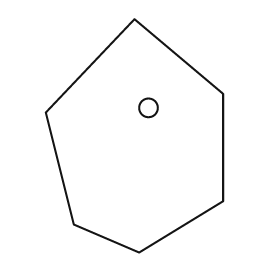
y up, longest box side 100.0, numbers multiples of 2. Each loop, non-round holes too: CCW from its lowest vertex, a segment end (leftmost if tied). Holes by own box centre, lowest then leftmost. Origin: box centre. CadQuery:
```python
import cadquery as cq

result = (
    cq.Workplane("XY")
    .moveTo(2.0, -50.0)
    .lineTo(38.0, -28.0)
    .lineTo(38.0, 18.0)
    .lineTo(0.0, 50.0)
    .lineTo(-38.0, 10.0)
    .lineTo(-26.0, -38.0)
    .close()
    .moveTo(6.0, 12.0)
    .circle(4.0)
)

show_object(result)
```